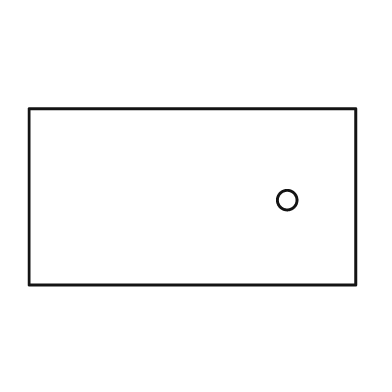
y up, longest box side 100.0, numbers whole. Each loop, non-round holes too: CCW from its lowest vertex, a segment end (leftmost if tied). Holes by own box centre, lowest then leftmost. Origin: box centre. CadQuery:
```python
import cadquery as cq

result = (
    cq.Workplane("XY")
    .moveTo(-50.0, -27.0)
    .lineTo(50.0, -27.0)
    .lineTo(50.0, 27.0)
    .lineTo(-50.0, 27.0)
    .close()
    .moveTo(29.0, -1.0)
    .circle(3.0)
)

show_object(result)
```